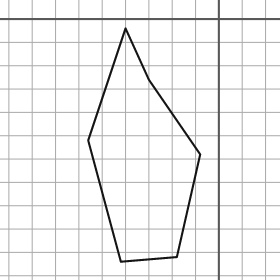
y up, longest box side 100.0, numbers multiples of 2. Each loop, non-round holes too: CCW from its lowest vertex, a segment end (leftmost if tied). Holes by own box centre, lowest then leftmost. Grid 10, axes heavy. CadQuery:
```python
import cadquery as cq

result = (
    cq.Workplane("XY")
    .moveTo(-42.0, -104.0)
    .lineTo(-18.0, -102.0)
    .lineTo(-8.0, -58.0)
    .lineTo(-30.0, -26.0)
    .lineTo(-40.0, -4.0)
    .lineTo(-56.0, -52.0)
    .close()
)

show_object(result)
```